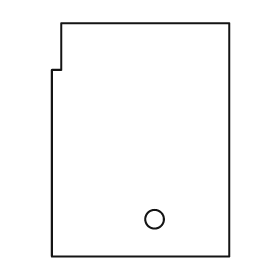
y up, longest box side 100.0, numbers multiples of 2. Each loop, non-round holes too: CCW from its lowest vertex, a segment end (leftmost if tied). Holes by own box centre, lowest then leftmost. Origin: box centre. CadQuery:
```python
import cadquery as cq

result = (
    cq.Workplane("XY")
    .moveTo(-38.0, -50.0)
    .lineTo(38.0, -50.0)
    .lineTo(38.0, 50.0)
    .lineTo(-34.0, 50.0)
    .lineTo(-34.0, 30.0)
    .lineTo(-38.0, 30.0)
    .close()
    .moveTo(6.0, -34.0)
    .circle(4.0)
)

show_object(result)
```